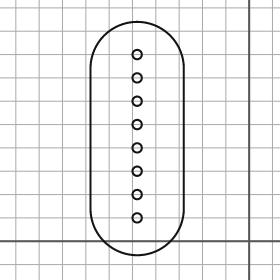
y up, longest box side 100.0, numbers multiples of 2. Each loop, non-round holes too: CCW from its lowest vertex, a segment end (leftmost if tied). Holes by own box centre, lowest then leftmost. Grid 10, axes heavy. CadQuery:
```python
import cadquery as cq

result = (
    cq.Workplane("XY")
    .moveTo(-68.0, 14.0)
    .threePointArc((-48.0, -6.0), (-28.0, 14.0))
    .lineTo(-28.0, 74.0)
    .threePointArc((-48.0, 94.0), (-68.0, 74.0))
    .close()
    .moveTo(-48.0, 10.0)
    .circle(2.0)
    .moveTo(-48.0, 20.0)
    .circle(2.0)
    .moveTo(-48.0, 30.0)
    .circle(2.0)
    .moveTo(-48.0, 40.0)
    .circle(2.0)
    .moveTo(-48.0, 50.0)
    .circle(2.0)
    .moveTo(-48.0, 60.0)
    .circle(2.0)
    .moveTo(-48.0, 70.0)
    .circle(2.0)
    .moveTo(-48.0, 80.0)
    .circle(2.0)
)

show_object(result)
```